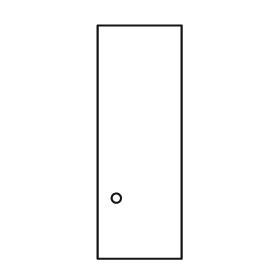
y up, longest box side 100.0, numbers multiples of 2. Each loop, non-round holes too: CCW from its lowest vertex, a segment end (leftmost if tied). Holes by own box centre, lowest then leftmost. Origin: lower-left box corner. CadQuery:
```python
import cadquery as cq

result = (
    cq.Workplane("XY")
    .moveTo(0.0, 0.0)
    .lineTo(36.0, 0.0)
    .lineTo(36.0, 100.0)
    .lineTo(0.0, 100.0)
    .close()
    .moveTo(8.0, 26.0)
    .circle(2.0)
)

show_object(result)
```